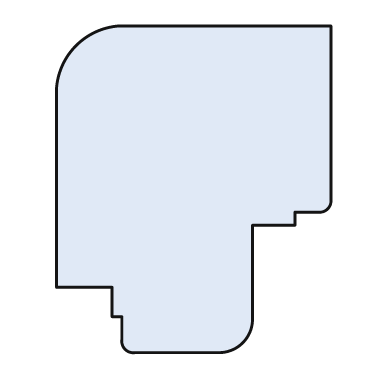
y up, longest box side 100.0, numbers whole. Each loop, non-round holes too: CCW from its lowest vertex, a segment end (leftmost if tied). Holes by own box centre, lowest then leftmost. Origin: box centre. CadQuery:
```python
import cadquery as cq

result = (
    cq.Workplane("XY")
    .moveTo(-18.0, -50.0)
    .lineTo(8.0, -50.0)
    .threePointArc((15.0, -47.0), (18.0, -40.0))
    .lineTo(18.0, -11.0)
    .lineTo(31.0, -11.0)
    .lineTo(31.0, -7.0)
    .lineTo(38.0, -7.0)
    .threePointArc((41.0, -6.0), (42.0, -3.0))
    .lineTo(42.0, 50.0)
    .lineTo(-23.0, 50.0)
    .threePointArc((-36.0, 44.0), (-42.0, 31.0))
    .lineTo(-42.0, -30.0)
    .lineTo(-25.0, -30.0)
    .lineTo(-25.0, -39.0)
    .lineTo(-22.0, -39.0)
    .lineTo(-22.0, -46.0)
    .threePointArc((-21.0, -49.0), (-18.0, -50.0))
    .close()
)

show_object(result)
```